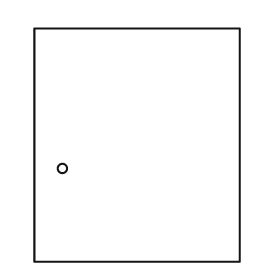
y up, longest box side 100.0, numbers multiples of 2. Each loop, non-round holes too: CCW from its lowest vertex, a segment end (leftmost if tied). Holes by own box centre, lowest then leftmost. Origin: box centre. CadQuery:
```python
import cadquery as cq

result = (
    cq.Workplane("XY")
    .moveTo(-44.0, -50.0)
    .lineTo(44.0, -50.0)
    .lineTo(44.0, 50.0)
    .lineTo(-44.0, 50.0)
    .close()
    .moveTo(-32.0, -10.0)
    .circle(2.0)
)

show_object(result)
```